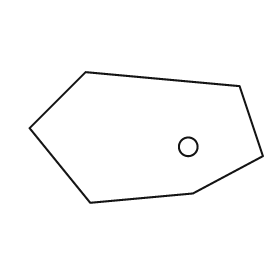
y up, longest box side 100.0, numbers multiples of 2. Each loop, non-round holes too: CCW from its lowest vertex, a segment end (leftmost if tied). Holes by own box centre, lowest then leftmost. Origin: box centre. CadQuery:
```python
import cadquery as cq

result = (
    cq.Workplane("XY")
    .moveTo(-24.0, -28.0)
    .lineTo(20.0, -24.0)
    .lineTo(50.0, -8.0)
    .lineTo(40.0, 22.0)
    .lineTo(-26.0, 28.0)
    .lineTo(-50.0, 4.0)
    .close()
    .moveTo(18.0, -4.0)
    .circle(4.0)
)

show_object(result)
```